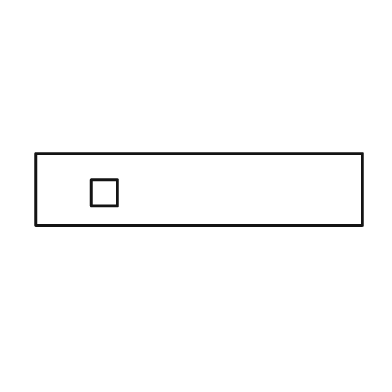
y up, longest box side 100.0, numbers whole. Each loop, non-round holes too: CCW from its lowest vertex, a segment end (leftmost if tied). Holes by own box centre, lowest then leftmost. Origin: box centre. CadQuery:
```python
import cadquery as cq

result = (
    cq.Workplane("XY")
    .moveTo(-50.0, -11.0)
    .lineTo(50.0, -11.0)
    .lineTo(50.0, 11.0)
    .lineTo(-50.0, 11.0)
    .close()
    .moveTo(-33.0, -5.0)
    .lineTo(-25.0, -5.0)
    .lineTo(-25.0, 3.0)
    .lineTo(-33.0, 3.0)
    .close()
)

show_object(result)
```